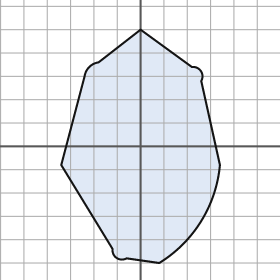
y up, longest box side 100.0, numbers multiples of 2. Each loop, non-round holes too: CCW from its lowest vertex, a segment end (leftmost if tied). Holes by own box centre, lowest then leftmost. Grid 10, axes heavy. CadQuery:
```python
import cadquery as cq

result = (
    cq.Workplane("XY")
    .moveTo(8.0, -50.0)
    .threePointArc((26.0, -32.0), (34.0, -8.0))
    .lineTo(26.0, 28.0)
    .threePointArc((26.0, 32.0), (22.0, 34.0))
    .lineTo(0.0, 50.0)
    .lineTo(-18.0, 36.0)
    .threePointArc((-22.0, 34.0), (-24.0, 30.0))
    .lineTo(-34.0, -8.0)
    .lineTo(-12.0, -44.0)
    .threePointArc((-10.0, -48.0), (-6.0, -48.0))
    .close()
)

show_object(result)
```